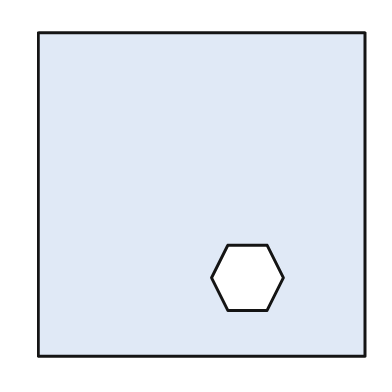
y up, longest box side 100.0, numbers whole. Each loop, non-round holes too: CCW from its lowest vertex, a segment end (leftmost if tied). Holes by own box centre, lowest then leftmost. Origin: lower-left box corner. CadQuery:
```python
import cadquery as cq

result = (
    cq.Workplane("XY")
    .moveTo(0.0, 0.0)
    .lineTo(100.0, 0.0)
    .lineTo(100.0, 99.0)
    .lineTo(0.0, 99.0)
    .close()
    .moveTo(58.0, 14.0)
    .lineTo(70.0, 14.0)
    .lineTo(75.0, 24.0)
    .lineTo(70.0, 34.0)
    .lineTo(58.0, 34.0)
    .lineTo(53.0, 24.0)
    .close()
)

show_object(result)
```